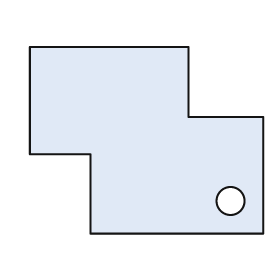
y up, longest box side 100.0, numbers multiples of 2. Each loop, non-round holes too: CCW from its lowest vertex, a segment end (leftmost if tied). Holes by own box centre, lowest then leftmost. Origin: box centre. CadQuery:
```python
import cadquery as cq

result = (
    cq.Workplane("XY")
    .moveTo(-24.0, -40.0)
    .lineTo(50.0, -40.0)
    .lineTo(50.0, 10.0)
    .lineTo(18.0, 10.0)
    .lineTo(18.0, 40.0)
    .lineTo(-50.0, 40.0)
    .lineTo(-50.0, -6.0)
    .lineTo(-24.0, -6.0)
    .close()
    .moveTo(36.0, -26.0)
    .circle(6.0)
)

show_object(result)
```